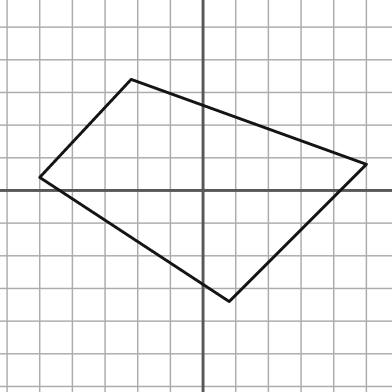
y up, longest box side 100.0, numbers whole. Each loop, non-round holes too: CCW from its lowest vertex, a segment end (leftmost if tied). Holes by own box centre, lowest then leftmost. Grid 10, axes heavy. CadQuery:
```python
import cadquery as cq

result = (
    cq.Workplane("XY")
    .moveTo(8.0, -34.0)
    .lineTo(50.0, 8.0)
    .lineTo(-22.0, 34.0)
    .lineTo(-50.0, 4.0)
    .close()
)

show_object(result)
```